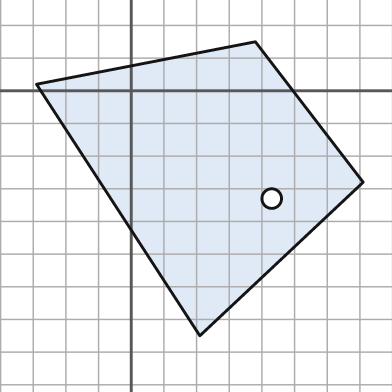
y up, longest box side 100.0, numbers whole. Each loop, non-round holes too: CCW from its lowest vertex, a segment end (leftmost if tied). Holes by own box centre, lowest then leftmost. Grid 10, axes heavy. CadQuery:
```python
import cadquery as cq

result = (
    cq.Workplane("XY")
    .moveTo(21.0, -75.0)
    .lineTo(71.0, -28.0)
    .lineTo(38.0, 15.0)
    .lineTo(-29.0, 2.0)
    .close()
    .moveTo(43.0, -33.0)
    .circle(3.0)
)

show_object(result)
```